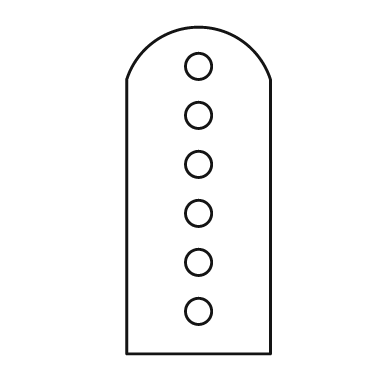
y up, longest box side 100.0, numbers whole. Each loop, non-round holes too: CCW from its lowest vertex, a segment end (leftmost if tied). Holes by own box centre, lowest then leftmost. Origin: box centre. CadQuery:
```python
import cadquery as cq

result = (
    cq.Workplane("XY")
    .moveTo(-22.0, -50.0)
    .lineTo(22.0, -50.0)
    .lineTo(22.0, 34.0)
    .threePointArc((0.0, 50.0), (-22.0, 34.0))
    .close()
    .moveTo(0.0, -37.0)
    .circle(4.0)
    .moveTo(0.0, -22.0)
    .circle(4.0)
    .moveTo(0.0, -7.0)
    .circle(4.0)
    .moveTo(0.0, 8.0)
    .circle(4.0)
    .moveTo(0.0, 23.0)
    .circle(4.0)
    .moveTo(0.0, 38.0)
    .circle(4.0)
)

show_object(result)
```